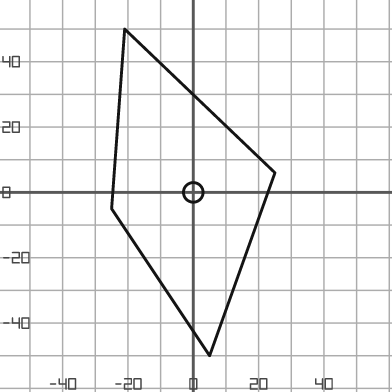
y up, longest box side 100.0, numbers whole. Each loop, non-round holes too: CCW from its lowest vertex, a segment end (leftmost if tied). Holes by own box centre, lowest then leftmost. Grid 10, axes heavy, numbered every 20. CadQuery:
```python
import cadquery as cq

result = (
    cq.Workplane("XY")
    .moveTo(5.0, -50.0)
    .lineTo(25.0, 6.0)
    .lineTo(-21.0, 50.0)
    .lineTo(-25.0, -5.0)
    .close()
    .moveTo(0.0, 0.0)
    .circle(3.0)
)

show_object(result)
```